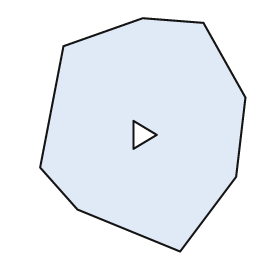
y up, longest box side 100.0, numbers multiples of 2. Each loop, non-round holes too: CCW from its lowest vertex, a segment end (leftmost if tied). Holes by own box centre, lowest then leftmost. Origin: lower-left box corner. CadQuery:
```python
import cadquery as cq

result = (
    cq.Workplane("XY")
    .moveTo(60.0, 0.0)
    .lineTo(84.0, 32.0)
    .lineTo(88.0, 66.0)
    .lineTo(70.0, 98.0)
    .lineTo(44.0, 100.0)
    .lineTo(10.0, 88.0)
    .lineTo(0.0, 36.0)
    .lineTo(16.0, 18.0)
    .close()
    .moveTo(40.0, 44.0)
    .lineTo(50.0, 50.0)
    .lineTo(40.0, 56.0)
    .close()
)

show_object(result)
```